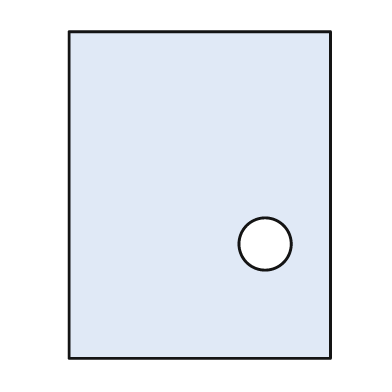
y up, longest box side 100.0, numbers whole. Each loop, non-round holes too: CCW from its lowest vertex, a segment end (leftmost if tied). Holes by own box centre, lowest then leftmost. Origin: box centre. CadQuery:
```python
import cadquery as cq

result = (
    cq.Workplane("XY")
    .moveTo(-40.0, -50.0)
    .lineTo(40.0, -50.0)
    .lineTo(40.0, 50.0)
    .lineTo(-40.0, 50.0)
    .close()
    .moveTo(20.0, -15.0)
    .circle(8.0)
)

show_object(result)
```